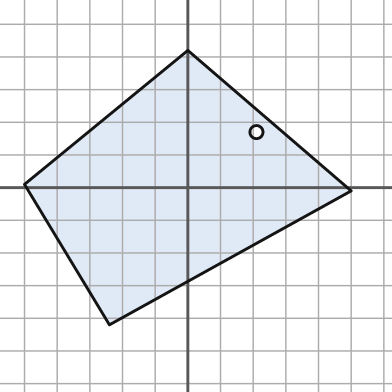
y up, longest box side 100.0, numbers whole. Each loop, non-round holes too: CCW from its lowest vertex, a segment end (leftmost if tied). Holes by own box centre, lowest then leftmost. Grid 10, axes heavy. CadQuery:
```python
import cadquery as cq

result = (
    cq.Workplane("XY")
    .moveTo(-24.0, -42.0)
    .lineTo(50.0, -1.0)
    .lineTo(0.0, 42.0)
    .lineTo(-50.0, 1.0)
    .close()
    .moveTo(21.0, 17.0)
    .circle(2.0)
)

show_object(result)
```